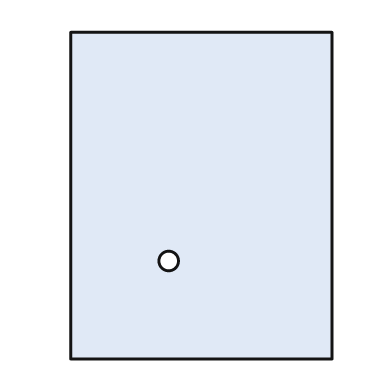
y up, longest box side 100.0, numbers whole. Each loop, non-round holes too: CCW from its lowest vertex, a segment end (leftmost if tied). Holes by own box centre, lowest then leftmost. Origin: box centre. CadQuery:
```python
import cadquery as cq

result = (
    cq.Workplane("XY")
    .moveTo(-40.0, -50.0)
    .lineTo(40.0, -50.0)
    .lineTo(40.0, 50.0)
    .lineTo(-40.0, 50.0)
    .close()
    .moveTo(-10.0, -20.0)
    .circle(3.0)
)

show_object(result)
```